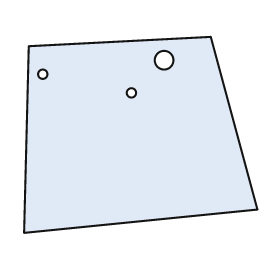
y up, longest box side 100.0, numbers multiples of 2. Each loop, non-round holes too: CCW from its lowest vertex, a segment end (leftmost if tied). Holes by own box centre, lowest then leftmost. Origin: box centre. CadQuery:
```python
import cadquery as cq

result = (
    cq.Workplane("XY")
    .moveTo(-50.0, -42.0)
    .lineTo(50.0, -32.0)
    .lineTo(30.0, 42.0)
    .lineTo(-48.0, 38.0)
    .close()
    .moveTo(-4.0, 18.0)
    .circle(2.0)
    .moveTo(-42.0, 26.0)
    .circle(2.0)
    .moveTo(10.0, 32.0)
    .circle(4.0)
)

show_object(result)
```